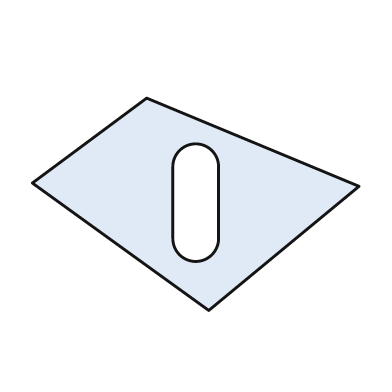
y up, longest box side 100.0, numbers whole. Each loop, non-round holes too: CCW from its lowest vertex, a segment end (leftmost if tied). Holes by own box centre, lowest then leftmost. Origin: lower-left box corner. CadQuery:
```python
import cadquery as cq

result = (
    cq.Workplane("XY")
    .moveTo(54.0, 0.0)
    .lineTo(100.0, 38.0)
    .lineTo(35.0, 65.0)
    .lineTo(0.0, 39.0)
    .close()
    .moveTo(43.0, 22.0)
    .threePointArc((50.0, 15.0), (57.0, 22.0))
    .lineTo(57.0, 44.0)
    .threePointArc((50.0, 51.0), (43.0, 44.0))
    .close()
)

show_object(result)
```